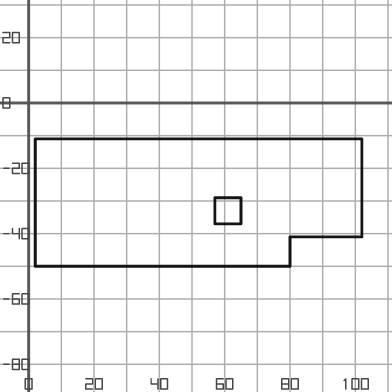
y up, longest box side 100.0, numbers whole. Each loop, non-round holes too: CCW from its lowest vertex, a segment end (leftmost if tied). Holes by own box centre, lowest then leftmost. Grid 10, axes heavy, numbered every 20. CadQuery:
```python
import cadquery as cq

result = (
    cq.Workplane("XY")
    .moveTo(2.0, -50.0)
    .lineTo(80.0, -50.0)
    .lineTo(80.0, -41.0)
    .lineTo(102.0, -41.0)
    .lineTo(102.0, -11.0)
    .lineTo(2.0, -11.0)
    .close()
    .moveTo(57.0, -37.0)
    .lineTo(65.0, -37.0)
    .lineTo(65.0, -29.0)
    .lineTo(57.0, -29.0)
    .close()
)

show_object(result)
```